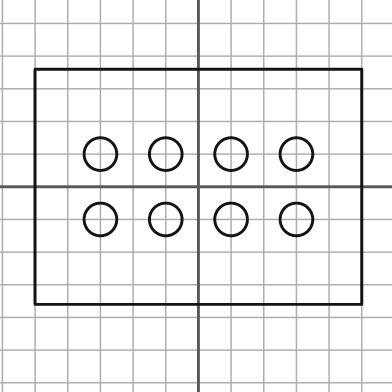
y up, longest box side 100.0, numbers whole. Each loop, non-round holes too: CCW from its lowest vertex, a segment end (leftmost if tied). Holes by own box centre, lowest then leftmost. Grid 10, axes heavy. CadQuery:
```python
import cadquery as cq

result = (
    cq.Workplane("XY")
    .moveTo(-50.0, -36.0)
    .lineTo(50.0, -36.0)
    .lineTo(50.0, 36.0)
    .lineTo(-50.0, 36.0)
    .close()
    .moveTo(-30.0, -10.0)
    .circle(5.0)
    .moveTo(-10.0, -10.0)
    .circle(5.0)
    .moveTo(10.0, -10.0)
    .circle(5.0)
    .moveTo(30.0, -10.0)
    .circle(5.0)
    .moveTo(-30.0, 10.0)
    .circle(5.0)
    .moveTo(-10.0, 10.0)
    .circle(5.0)
    .moveTo(10.0, 10.0)
    .circle(5.0)
    .moveTo(30.0, 10.0)
    .circle(5.0)
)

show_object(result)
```